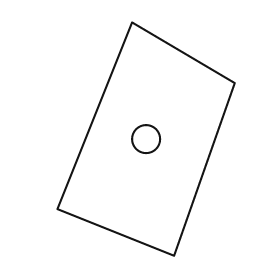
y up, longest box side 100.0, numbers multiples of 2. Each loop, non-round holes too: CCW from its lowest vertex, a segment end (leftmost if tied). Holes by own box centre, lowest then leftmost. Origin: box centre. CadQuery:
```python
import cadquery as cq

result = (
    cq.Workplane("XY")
    .moveTo(12.0, -50.0)
    .lineTo(38.0, 24.0)
    .lineTo(-6.0, 50.0)
    .lineTo(-38.0, -30.0)
    .close()
    .moveTo(0.0, 0.0)
    .circle(6.0)
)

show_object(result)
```